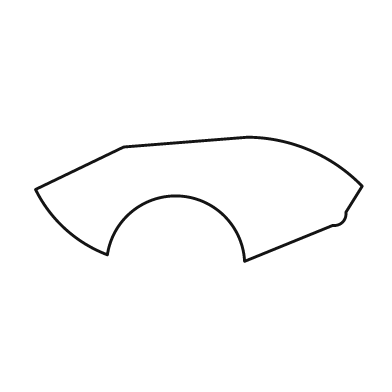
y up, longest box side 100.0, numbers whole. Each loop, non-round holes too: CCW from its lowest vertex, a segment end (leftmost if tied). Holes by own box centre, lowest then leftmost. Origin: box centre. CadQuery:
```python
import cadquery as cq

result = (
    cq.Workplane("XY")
    .moveTo(14.0, -19.0)
    .lineTo(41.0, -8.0)
    .threePointArc((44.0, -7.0), (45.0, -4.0))
    .lineTo(50.0, 4.0)
    .threePointArc((34.0, 15.0), (15.0, 19.0))
    .lineTo(-23.0, 16.0)
    .lineTo(-50.0, 3.0)
    .threePointArc((-41.0, -9.0), (-28.0, -17.0))
    .threePointArc((-6.0, 1.0), (14.0, -19.0))
    .close()
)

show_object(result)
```